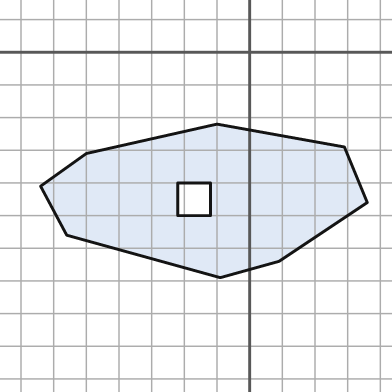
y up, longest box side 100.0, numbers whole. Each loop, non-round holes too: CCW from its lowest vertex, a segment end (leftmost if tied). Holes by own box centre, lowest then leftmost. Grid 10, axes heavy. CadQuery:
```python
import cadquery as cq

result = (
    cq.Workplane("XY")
    .moveTo(-9.0, -69.0)
    .lineTo(9.0, -64.0)
    .lineTo(36.0, -46.0)
    .lineTo(29.0, -29.0)
    .lineTo(-10.0, -22.0)
    .lineTo(-50.0, -31.0)
    .lineTo(-64.0, -41.0)
    .lineTo(-56.0, -56.0)
    .close()
    .moveTo(-22.0, -50.0)
    .lineTo(-12.0, -50.0)
    .lineTo(-12.0, -40.0)
    .lineTo(-22.0, -40.0)
    .close()
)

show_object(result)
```